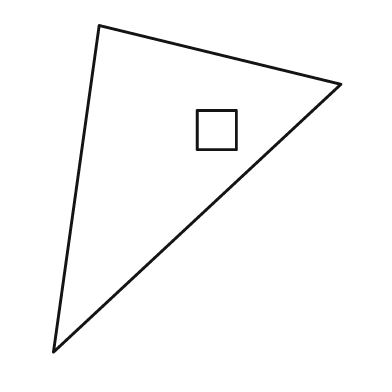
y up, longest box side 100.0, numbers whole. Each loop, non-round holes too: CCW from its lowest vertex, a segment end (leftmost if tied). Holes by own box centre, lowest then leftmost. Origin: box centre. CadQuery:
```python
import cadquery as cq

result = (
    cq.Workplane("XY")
    .moveTo(-44.0, -50.0)
    .lineTo(44.0, 32.0)
    .lineTo(-30.0, 50.0)
    .close()
    .moveTo(0.0, 12.0)
    .lineTo(12.0, 12.0)
    .lineTo(12.0, 24.0)
    .lineTo(0.0, 24.0)
    .close()
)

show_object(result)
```